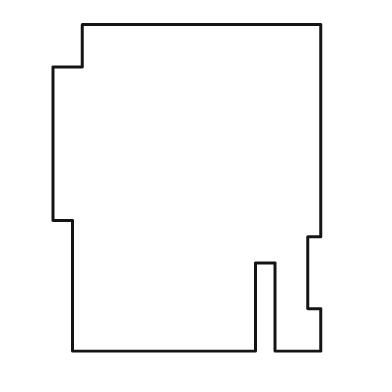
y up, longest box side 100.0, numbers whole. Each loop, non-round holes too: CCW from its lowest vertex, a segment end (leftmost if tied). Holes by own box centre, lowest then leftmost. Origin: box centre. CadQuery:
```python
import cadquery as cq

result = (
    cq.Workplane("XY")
    .moveTo(-35.0, -50.0)
    .lineTo(21.0, -50.0)
    .lineTo(21.0, -23.0)
    .lineTo(27.0, -23.0)
    .lineTo(27.0, -50.0)
    .lineTo(41.0, -50.0)
    .lineTo(41.0, -37.0)
    .lineTo(37.0, -37.0)
    .lineTo(37.0, -15.0)
    .lineTo(41.0, -15.0)
    .lineTo(41.0, 50.0)
    .lineTo(-32.0, 50.0)
    .lineTo(-32.0, 37.0)
    .lineTo(-41.0, 37.0)
    .lineTo(-41.0, -10.0)
    .lineTo(-35.0, -10.0)
    .close()
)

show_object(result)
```